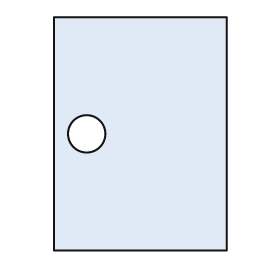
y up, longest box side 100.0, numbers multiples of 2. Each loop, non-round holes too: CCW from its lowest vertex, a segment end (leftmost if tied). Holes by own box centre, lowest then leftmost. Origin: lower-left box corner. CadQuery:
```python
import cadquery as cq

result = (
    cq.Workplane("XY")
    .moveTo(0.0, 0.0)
    .lineTo(74.0, 0.0)
    .lineTo(74.0, 100.0)
    .lineTo(0.0, 100.0)
    .close()
    .moveTo(14.0, 50.0)
    .circle(8.0)
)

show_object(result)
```